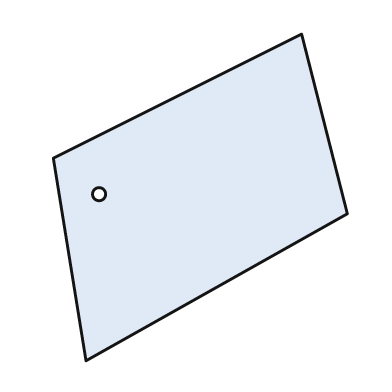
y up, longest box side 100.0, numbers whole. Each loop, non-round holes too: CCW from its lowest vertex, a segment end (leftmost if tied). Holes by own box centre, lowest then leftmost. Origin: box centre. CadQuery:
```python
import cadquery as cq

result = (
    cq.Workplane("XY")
    .moveTo(-35.0, -50.0)
    .lineTo(45.0, -5.0)
    .lineTo(31.0, 50.0)
    .lineTo(-45.0, 12.0)
    .close()
    .moveTo(-31.0, 1.0)
    .circle(2.0)
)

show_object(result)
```